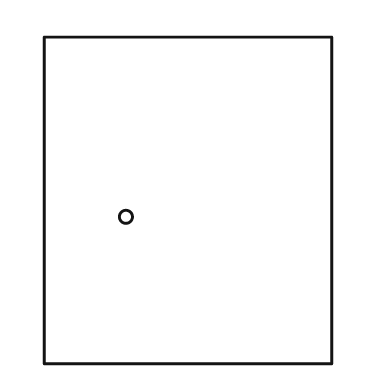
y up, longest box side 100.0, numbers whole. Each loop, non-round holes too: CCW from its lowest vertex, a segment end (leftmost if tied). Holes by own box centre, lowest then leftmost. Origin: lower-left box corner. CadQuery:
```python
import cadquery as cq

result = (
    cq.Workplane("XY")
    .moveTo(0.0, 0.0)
    .lineTo(88.0, 0.0)
    .lineTo(88.0, 100.0)
    .lineTo(0.0, 100.0)
    .close()
    .moveTo(25.0, 45.0)
    .circle(2.0)
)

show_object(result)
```